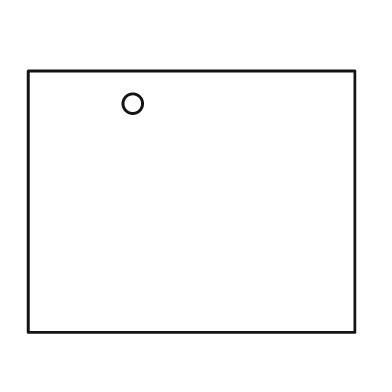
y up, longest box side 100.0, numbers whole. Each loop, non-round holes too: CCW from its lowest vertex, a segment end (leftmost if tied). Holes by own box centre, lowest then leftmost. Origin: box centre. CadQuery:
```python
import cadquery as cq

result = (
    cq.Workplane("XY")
    .moveTo(-50.0, -40.0)
    .lineTo(50.0, -40.0)
    .lineTo(50.0, 40.0)
    .lineTo(-50.0, 40.0)
    .close()
    .moveTo(-18.0, 30.0)
    .circle(3.0)
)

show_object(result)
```